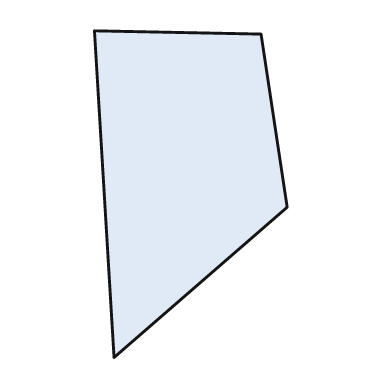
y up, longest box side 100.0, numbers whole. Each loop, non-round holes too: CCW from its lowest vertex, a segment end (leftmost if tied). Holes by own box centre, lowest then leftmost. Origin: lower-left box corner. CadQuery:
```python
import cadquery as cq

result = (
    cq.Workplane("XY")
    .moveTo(6.0, 0.0)
    .lineTo(59.0, 46.0)
    .lineTo(51.0, 99.0)
    .lineTo(0.0, 100.0)
    .close()
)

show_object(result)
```